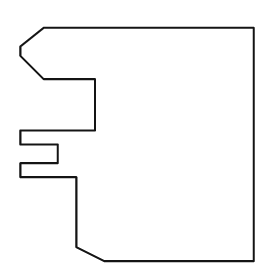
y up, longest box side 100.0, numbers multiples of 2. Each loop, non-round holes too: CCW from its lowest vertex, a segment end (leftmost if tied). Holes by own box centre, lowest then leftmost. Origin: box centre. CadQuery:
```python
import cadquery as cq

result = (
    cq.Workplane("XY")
    .moveTo(-14.0, -50.0)
    .lineTo(50.0, -50.0)
    .lineTo(50.0, 50.0)
    .lineTo(-40.0, 50.0)
    .lineTo(-50.0, 42.0)
    .lineTo(-50.0, 38.0)
    .lineTo(-40.0, 28.0)
    .lineTo(-18.0, 28.0)
    .lineTo(-18.0, 6.0)
    .lineTo(-50.0, 6.0)
    .lineTo(-50.0, 0.0)
    .lineTo(-34.0, 0.0)
    .lineTo(-34.0, -8.0)
    .lineTo(-50.0, -8.0)
    .lineTo(-50.0, -14.0)
    .lineTo(-26.0, -14.0)
    .lineTo(-26.0, -44.0)
    .close()
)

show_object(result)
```